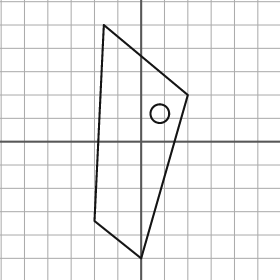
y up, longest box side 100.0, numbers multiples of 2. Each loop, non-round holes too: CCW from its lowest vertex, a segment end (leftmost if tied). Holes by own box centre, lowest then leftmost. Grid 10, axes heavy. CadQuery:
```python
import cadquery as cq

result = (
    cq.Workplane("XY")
    .moveTo(0.0, -50.0)
    .lineTo(20.0, 20.0)
    .lineTo(-16.0, 50.0)
    .lineTo(-20.0, -34.0)
    .close()
    .moveTo(8.0, 12.0)
    .circle(4.0)
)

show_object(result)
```